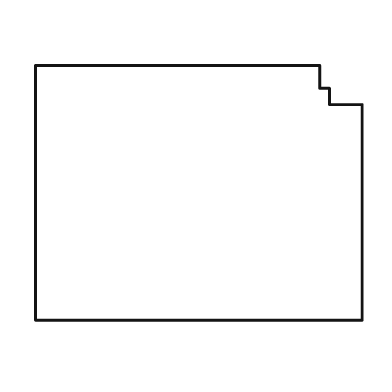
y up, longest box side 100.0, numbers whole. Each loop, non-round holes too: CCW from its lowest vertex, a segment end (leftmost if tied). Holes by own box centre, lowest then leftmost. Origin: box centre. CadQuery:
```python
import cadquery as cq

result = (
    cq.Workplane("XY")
    .moveTo(-50.0, -39.0)
    .lineTo(50.0, -39.0)
    .lineTo(50.0, 27.0)
    .lineTo(40.0, 27.0)
    .lineTo(40.0, 32.0)
    .lineTo(37.0, 32.0)
    .lineTo(37.0, 39.0)
    .lineTo(-50.0, 39.0)
    .close()
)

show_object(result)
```